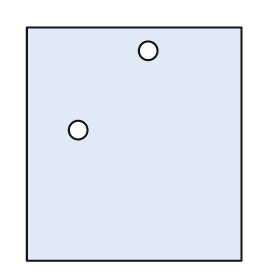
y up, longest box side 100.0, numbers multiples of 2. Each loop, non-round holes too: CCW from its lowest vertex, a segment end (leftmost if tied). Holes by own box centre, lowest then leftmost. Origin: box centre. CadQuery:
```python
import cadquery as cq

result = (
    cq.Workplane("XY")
    .moveTo(-46.0, -50.0)
    .lineTo(46.0, -50.0)
    .lineTo(46.0, 50.0)
    .lineTo(-46.0, 50.0)
    .close()
    .moveTo(-24.0, 6.0)
    .circle(4.0)
    .moveTo(6.0, 40.0)
    .circle(4.0)
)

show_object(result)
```